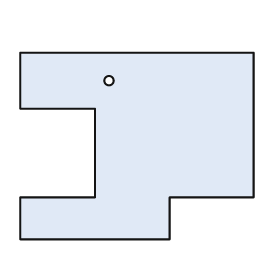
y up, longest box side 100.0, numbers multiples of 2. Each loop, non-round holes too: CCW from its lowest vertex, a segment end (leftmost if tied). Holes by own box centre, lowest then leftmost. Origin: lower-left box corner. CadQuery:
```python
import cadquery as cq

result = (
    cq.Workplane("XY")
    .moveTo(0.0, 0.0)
    .lineTo(64.0, 0.0)
    .lineTo(64.0, 18.0)
    .lineTo(100.0, 18.0)
    .lineTo(100.0, 80.0)
    .lineTo(0.0, 80.0)
    .lineTo(0.0, 56.0)
    .lineTo(32.0, 56.0)
    .lineTo(32.0, 18.0)
    .lineTo(0.0, 18.0)
    .close()
    .moveTo(38.0, 68.0)
    .circle(2.0)
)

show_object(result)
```